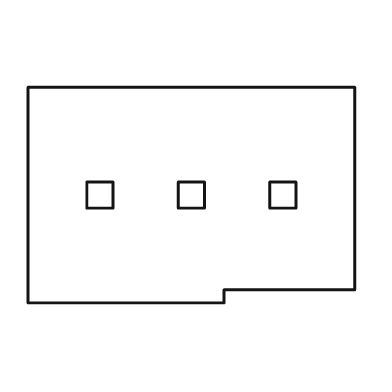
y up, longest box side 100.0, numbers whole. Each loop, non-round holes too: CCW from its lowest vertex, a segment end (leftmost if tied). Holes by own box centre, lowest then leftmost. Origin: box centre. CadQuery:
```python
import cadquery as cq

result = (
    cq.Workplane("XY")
    .moveTo(-50.0, -33.0)
    .lineTo(10.0, -33.0)
    .lineTo(10.0, -29.0)
    .lineTo(50.0, -29.0)
    .lineTo(50.0, 33.0)
    .lineTo(-50.0, 33.0)
    .close()
    .moveTo(-32.0, -4.0)
    .lineTo(-24.0, -4.0)
    .lineTo(-24.0, 4.0)
    .lineTo(-32.0, 4.0)
    .close()
    .moveTo(-4.0, -4.0)
    .lineTo(4.0, -4.0)
    .lineTo(4.0, 4.0)
    .lineTo(-4.0, 4.0)
    .close()
    .moveTo(24.0, -4.0)
    .lineTo(32.0, -4.0)
    .lineTo(32.0, 4.0)
    .lineTo(24.0, 4.0)
    .close()
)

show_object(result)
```